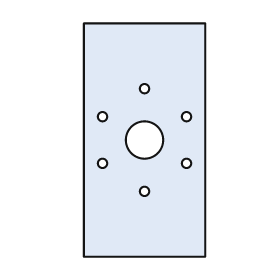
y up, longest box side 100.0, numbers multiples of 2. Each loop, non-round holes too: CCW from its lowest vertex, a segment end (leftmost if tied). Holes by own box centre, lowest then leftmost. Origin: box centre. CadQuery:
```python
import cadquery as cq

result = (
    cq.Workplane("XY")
    .moveTo(-26.0, -50.0)
    .lineTo(26.0, -50.0)
    .lineTo(26.0, 50.0)
    .lineTo(-26.0, 50.0)
    .close()
    .moveTo(0.0, -22.0)
    .circle(2.0)
    .moveTo(-18.0, -10.0)
    .circle(2.0)
    .moveTo(18.0, -10.0)
    .circle(2.0)
    .moveTo(0.0, 0.0)
    .circle(8.0)
    .moveTo(-18.0, 10.0)
    .circle(2.0)
    .moveTo(18.0, 10.0)
    .circle(2.0)
    .moveTo(0.0, 22.0)
    .circle(2.0)
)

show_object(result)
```